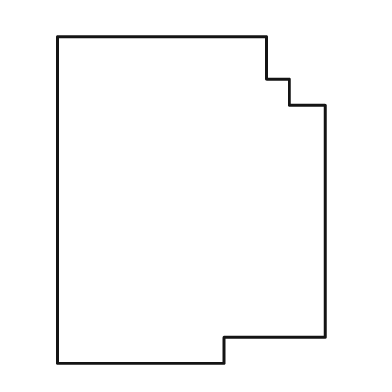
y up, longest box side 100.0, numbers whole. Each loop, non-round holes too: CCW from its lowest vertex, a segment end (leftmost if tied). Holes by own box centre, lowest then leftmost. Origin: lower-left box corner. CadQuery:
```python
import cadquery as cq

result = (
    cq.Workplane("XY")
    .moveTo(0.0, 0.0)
    .lineTo(51.0, 0.0)
    .lineTo(51.0, 8.0)
    .lineTo(82.0, 8.0)
    .lineTo(82.0, 79.0)
    .lineTo(71.0, 79.0)
    .lineTo(71.0, 87.0)
    .lineTo(64.0, 87.0)
    .lineTo(64.0, 100.0)
    .lineTo(0.0, 100.0)
    .close()
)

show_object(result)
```